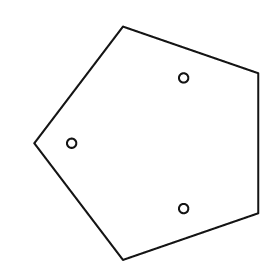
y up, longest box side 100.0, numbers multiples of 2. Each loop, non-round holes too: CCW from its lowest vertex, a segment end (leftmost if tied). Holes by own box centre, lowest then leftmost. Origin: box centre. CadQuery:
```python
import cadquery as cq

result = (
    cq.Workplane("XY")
    .moveTo(-10.0, -50.0)
    .lineTo(48.0, -30.0)
    .lineTo(48.0, 30.0)
    .lineTo(-10.0, 50.0)
    .lineTo(-48.0, 0.0)
    .close()
    .moveTo(16.0, -28.0)
    .circle(2.0)
    .moveTo(-32.0, 0.0)
    .circle(2.0)
    .moveTo(16.0, 28.0)
    .circle(2.0)
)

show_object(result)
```